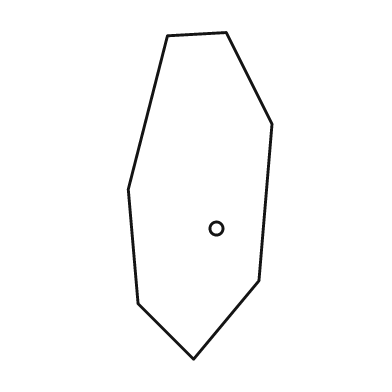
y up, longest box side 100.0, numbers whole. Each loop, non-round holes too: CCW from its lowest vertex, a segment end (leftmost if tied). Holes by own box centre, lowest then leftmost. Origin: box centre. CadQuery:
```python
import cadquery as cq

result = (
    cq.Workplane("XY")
    .moveTo(-2.0, -50.0)
    .lineTo(18.0, -26.0)
    .lineTo(22.0, 22.0)
    .lineTo(8.0, 50.0)
    .lineTo(-10.0, 49.0)
    .lineTo(-22.0, 2.0)
    .lineTo(-19.0, -33.0)
    .close()
    .moveTo(5.0, -10.0)
    .circle(2.0)
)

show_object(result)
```